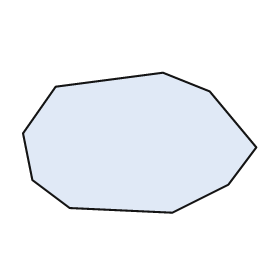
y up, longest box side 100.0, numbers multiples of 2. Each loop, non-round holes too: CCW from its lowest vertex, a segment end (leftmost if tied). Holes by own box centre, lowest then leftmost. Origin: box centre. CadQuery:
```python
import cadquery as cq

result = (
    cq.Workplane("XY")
    .moveTo(14.0, -30.0)
    .lineTo(38.0, -18.0)
    .lineTo(50.0, -2.0)
    .lineTo(30.0, 22.0)
    .lineTo(10.0, 30.0)
    .lineTo(-36.0, 24.0)
    .lineTo(-50.0, 4.0)
    .lineTo(-46.0, -16.0)
    .lineTo(-30.0, -28.0)
    .close()
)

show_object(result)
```